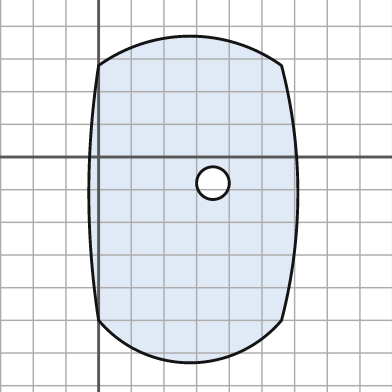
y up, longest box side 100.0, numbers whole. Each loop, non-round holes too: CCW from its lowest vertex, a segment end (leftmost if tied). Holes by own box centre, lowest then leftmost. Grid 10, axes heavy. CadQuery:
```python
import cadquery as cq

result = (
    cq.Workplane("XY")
    .moveTo(0.0, -50.0)
    .threePointArc((28.0, -63.0), (56.0, -50.0))
    .threePointArc((61.0, -11.0), (56.0, 28.0))
    .threePointArc((28.0, 37.0), (0.0, 28.0))
    .threePointArc((-3.0, -11.0), (0.0, -50.0))
    .close()
    .moveTo(35.0, -8.0)
    .circle(5.0)
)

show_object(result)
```